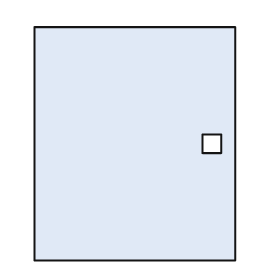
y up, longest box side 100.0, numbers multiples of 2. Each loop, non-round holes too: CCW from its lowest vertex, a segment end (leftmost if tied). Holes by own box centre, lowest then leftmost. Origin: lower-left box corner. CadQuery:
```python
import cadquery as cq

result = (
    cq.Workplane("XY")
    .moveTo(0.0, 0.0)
    .lineTo(86.0, 0.0)
    .lineTo(86.0, 100.0)
    .lineTo(0.0, 100.0)
    .close()
    .moveTo(72.0, 46.0)
    .lineTo(80.0, 46.0)
    .lineTo(80.0, 54.0)
    .lineTo(72.0, 54.0)
    .close()
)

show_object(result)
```